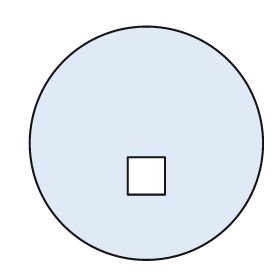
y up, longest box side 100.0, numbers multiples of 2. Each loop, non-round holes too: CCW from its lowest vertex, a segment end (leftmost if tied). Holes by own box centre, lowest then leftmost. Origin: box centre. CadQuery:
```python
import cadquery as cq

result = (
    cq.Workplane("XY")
    .moveTo(0.0, 0.0)
    .circle(50.0)
    .moveTo(-8.0, -22.0)
    .lineTo(8.0, -22.0)
    .lineTo(8.0, -6.0)
    .lineTo(-8.0, -6.0)
    .close()
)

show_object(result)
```